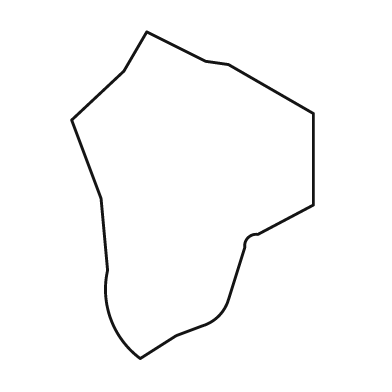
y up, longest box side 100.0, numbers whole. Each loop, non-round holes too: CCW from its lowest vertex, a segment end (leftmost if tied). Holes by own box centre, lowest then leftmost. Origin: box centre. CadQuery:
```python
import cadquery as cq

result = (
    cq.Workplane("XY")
    .moveTo(-16.0, -50.0)
    .lineTo(-5.0, -43.0)
    .lineTo(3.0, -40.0)
    .threePointArc((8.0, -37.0), (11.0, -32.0))
    .lineTo(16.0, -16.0)
    .threePointArc((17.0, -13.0), (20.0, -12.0))
    .lineTo(37.0, -3.0)
    .lineTo(37.0, 25.0)
    .lineTo(11.0, 40.0)
    .lineTo(4.0, 41.0)
    .lineTo(-14.0, 50.0)
    .lineTo(-21.0, 38.0)
    .lineTo(-37.0, 23.0)
    .lineTo(-28.0, -1.0)
    .lineTo(-26.0, -23.0)
    .threePointArc((-25.0, -38.0), (-16.0, -50.0))
    .close()
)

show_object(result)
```